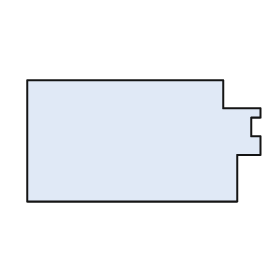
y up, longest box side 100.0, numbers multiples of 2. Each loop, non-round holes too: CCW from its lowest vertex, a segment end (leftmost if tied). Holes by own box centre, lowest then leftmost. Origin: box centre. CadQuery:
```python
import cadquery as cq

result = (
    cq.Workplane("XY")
    .moveTo(-50.0, -26.0)
    .lineTo(40.0, -26.0)
    .lineTo(40.0, -6.0)
    .lineTo(50.0, -6.0)
    .lineTo(50.0, 2.0)
    .lineTo(46.0, 2.0)
    .lineTo(46.0, 10.0)
    .lineTo(50.0, 10.0)
    .lineTo(50.0, 14.0)
    .lineTo(34.0, 14.0)
    .lineTo(34.0, 26.0)
    .lineTo(-50.0, 26.0)
    .close()
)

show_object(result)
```